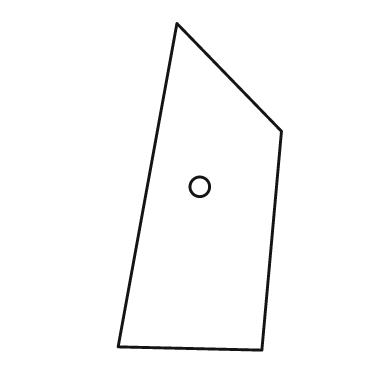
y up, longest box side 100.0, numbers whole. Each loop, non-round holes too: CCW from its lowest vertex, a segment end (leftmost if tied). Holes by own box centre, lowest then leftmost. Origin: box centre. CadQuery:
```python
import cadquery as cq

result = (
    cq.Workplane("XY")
    .moveTo(19.0, -50.0)
    .lineTo(25.0, 17.0)
    .lineTo(-7.0, 50.0)
    .lineTo(-25.0, -49.0)
    .close()
    .moveTo(0.0, 0.0)
    .circle(3.0)
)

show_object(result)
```